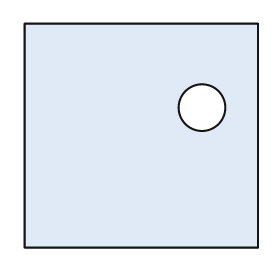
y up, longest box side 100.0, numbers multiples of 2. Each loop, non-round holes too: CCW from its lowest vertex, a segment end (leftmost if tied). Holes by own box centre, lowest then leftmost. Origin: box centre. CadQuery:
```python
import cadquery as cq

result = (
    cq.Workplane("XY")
    .moveTo(-50.0, -48.0)
    .lineTo(50.0, -48.0)
    .lineTo(50.0, 48.0)
    .lineTo(-50.0, 48.0)
    .close()
    .moveTo(26.0, 12.0)
    .circle(10.0)
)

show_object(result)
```